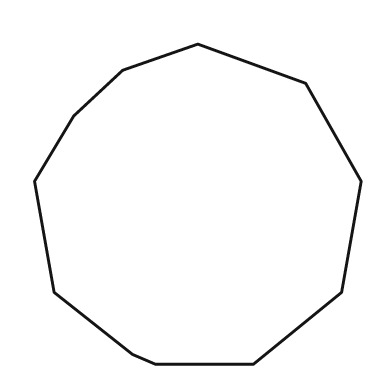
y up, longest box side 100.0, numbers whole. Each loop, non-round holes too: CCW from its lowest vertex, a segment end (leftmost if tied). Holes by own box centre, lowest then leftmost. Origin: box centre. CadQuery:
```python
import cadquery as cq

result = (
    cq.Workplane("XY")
    .moveTo(-13.0, -49.0)
    .lineTo(17.0, -49.0)
    .lineTo(44.0, -27.0)
    .lineTo(50.0, 7.0)
    .lineTo(33.0, 37.0)
    .lineTo(0.0, 49.0)
    .lineTo(-23.0, 41.0)
    .lineTo(-38.0, 27.0)
    .lineTo(-50.0, 7.0)
    .lineTo(-44.0, -27.0)
    .lineTo(-20.0, -46.0)
    .close()
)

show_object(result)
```